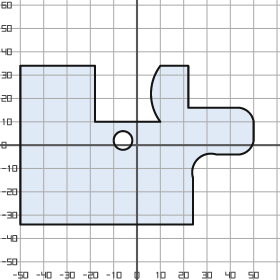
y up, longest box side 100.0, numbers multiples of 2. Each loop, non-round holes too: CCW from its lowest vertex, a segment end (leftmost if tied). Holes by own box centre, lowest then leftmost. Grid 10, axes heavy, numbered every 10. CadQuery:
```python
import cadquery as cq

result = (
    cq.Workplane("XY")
    .moveTo(-50.0, -34.0)
    .lineTo(24.0, -34.0)
    .lineTo(24.0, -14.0)
    .threePointArc((26.0, -6.0), (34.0, -4.0))
    .lineTo(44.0, -4.0)
    .threePointArc((48.0, -2.0), (50.0, 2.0))
    .lineTo(50.0, 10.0)
    .threePointArc((48.0, 14.0), (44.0, 16.0))
    .lineTo(22.0, 16.0)
    .lineTo(22.0, 34.0)
    .lineTo(10.0, 34.0)
    .threePointArc((6.0, 22.0), (10.0, 10.0))
    .lineTo(-18.0, 10.0)
    .lineTo(-18.0, 34.0)
    .lineTo(-50.0, 34.0)
    .close()
    .moveTo(-6.0, 2.0)
    .circle(4.0)
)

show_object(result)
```